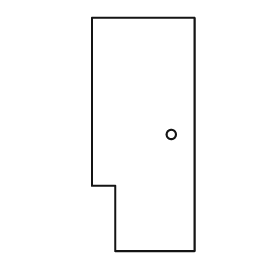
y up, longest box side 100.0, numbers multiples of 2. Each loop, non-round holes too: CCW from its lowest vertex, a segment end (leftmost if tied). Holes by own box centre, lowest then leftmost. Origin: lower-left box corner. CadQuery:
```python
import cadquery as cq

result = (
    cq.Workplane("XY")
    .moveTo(10.0, 0.0)
    .lineTo(44.0, 0.0)
    .lineTo(44.0, 100.0)
    .lineTo(0.0, 100.0)
    .lineTo(0.0, 28.0)
    .lineTo(10.0, 28.0)
    .close()
    .moveTo(34.0, 50.0)
    .circle(2.0)
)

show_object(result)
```